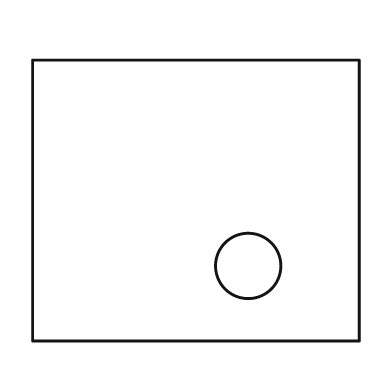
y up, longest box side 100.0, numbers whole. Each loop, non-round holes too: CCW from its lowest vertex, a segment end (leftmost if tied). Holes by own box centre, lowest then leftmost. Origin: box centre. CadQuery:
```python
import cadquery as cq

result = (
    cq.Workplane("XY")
    .moveTo(-50.0, -43.0)
    .lineTo(50.0, -43.0)
    .lineTo(50.0, 43.0)
    .lineTo(-50.0, 43.0)
    .close()
    .moveTo(16.0, -20.0)
    .circle(10.0)
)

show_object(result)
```